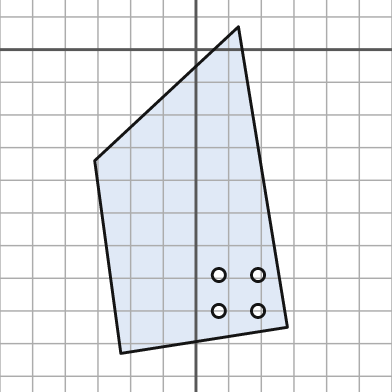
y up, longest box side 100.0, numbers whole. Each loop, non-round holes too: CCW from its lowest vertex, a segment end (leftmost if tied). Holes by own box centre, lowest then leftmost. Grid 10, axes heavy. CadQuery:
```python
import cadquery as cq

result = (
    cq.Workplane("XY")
    .moveTo(-23.0, -93.0)
    .lineTo(28.0, -85.0)
    .lineTo(13.0, 7.0)
    .lineTo(-31.0, -34.0)
    .close()
    .moveTo(7.0, -80.0)
    .circle(2.0)
    .moveTo(19.0, -80.0)
    .circle(2.0)
    .moveTo(7.0, -69.0)
    .circle(2.0)
    .moveTo(19.0, -69.0)
    .circle(2.0)
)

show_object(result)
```